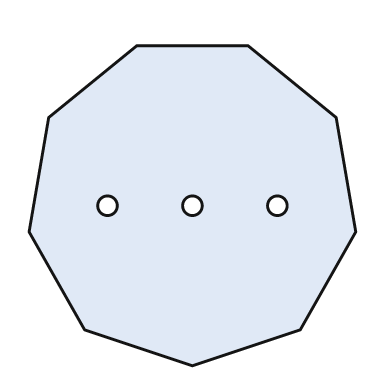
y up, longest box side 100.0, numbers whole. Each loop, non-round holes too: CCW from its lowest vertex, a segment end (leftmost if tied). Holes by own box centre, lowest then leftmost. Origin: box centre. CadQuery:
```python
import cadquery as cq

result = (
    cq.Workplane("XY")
    .moveTo(0.0, -49.0)
    .lineTo(33.0, -38.0)
    .lineTo(50.0, -8.0)
    .lineTo(44.0, 27.0)
    .lineTo(17.0, 49.0)
    .lineTo(-17.0, 49.0)
    .lineTo(-44.0, 27.0)
    .lineTo(-50.0, -8.0)
    .lineTo(-33.0, -38.0)
    .close()
    .moveTo(-26.0, 0.0)
    .circle(3.0)
    .moveTo(0.0, 0.0)
    .circle(3.0)
    .moveTo(26.0, 0.0)
    .circle(3.0)
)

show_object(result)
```